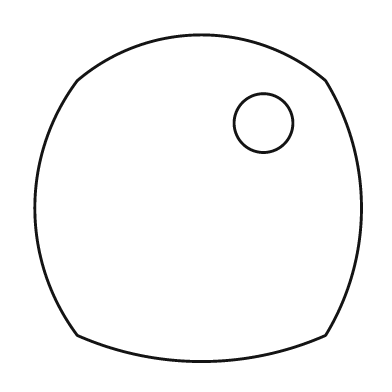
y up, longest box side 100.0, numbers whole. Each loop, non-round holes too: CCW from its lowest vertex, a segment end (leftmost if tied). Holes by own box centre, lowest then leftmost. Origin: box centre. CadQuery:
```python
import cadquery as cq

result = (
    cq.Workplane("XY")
    .moveTo(-37.0, -42.0)
    .threePointArc((1.0, -50.0), (39.0, -42.0))
    .threePointArc((50.0, -3.0), (39.0, 36.0))
    .threePointArc((1.0, 50.0), (-37.0, 36.0))
    .threePointArc((-50.0, -3.0), (-37.0, -42.0))
    .close()
    .moveTo(20.0, 23.0)
    .circle(9.0)
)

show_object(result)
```